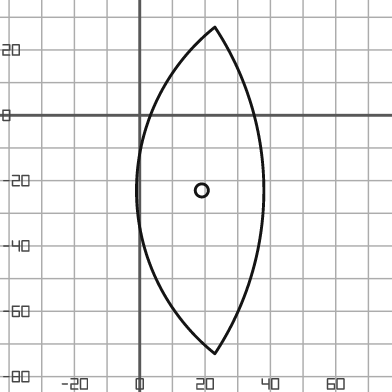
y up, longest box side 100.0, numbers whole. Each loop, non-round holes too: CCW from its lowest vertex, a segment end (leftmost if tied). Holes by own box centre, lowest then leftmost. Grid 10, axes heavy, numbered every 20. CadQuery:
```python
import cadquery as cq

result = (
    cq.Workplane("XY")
    .moveTo(23.0, -73.0)
    .threePointArc((38.0, -23.0), (23.0, 27.0))
    .threePointArc((-1.0, -23.0), (23.0, -73.0))
    .close()
    .moveTo(19.0, -23.0)
    .circle(2.0)
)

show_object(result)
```